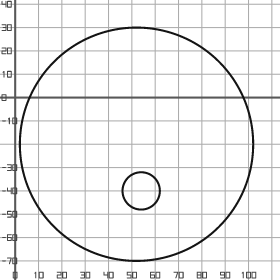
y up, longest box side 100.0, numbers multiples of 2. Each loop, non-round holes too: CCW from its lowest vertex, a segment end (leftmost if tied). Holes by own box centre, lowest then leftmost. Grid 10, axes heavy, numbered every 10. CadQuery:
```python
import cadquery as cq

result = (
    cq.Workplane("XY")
    .moveTo(52.0, -20.0)
    .circle(50.0)
    .moveTo(54.0, -40.0)
    .circle(8.0)
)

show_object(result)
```